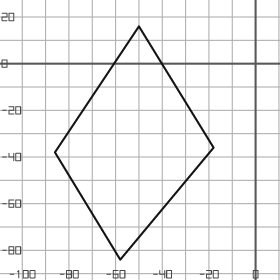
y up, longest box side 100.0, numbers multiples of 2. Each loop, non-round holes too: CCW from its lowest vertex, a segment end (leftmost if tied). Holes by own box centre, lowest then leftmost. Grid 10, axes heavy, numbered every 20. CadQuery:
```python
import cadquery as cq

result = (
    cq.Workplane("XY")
    .moveTo(-58.0, -84.0)
    .lineTo(-18.0, -36.0)
    .lineTo(-50.0, 16.0)
    .lineTo(-86.0, -38.0)
    .close()
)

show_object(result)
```